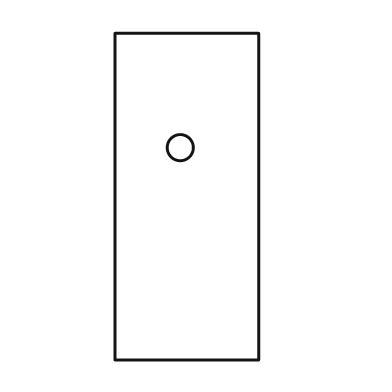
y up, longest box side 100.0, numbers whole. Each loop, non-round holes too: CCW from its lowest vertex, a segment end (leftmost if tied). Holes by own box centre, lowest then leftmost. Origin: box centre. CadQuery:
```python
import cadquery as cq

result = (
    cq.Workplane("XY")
    .moveTo(-22.0, -50.0)
    .lineTo(22.0, -50.0)
    .lineTo(22.0, 50.0)
    .lineTo(-22.0, 50.0)
    .close()
    .moveTo(-2.0, 15.0)
    .circle(4.0)
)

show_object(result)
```